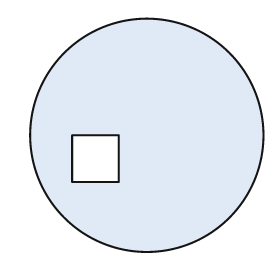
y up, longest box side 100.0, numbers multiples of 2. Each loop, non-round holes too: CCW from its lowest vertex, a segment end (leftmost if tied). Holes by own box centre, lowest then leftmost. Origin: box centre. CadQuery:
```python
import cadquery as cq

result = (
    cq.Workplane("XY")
    .moveTo(0.0, 0.0)
    .circle(50.0)
    .moveTo(-32.0, -20.0)
    .lineTo(-12.0, -20.0)
    .lineTo(-12.0, 0.0)
    .lineTo(-32.0, 0.0)
    .close()
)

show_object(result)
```